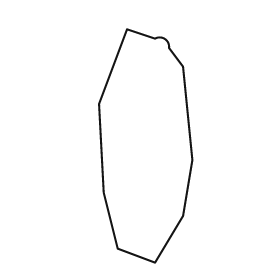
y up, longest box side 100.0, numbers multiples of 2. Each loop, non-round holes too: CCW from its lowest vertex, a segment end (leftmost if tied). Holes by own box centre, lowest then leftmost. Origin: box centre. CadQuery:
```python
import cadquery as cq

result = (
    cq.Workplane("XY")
    .moveTo(4.0, -50.0)
    .lineTo(16.0, -30.0)
    .lineTo(20.0, -6.0)
    .lineTo(16.0, 34.0)
    .lineTo(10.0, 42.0)
    .threePointArc((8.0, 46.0), (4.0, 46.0))
    .lineTo(-8.0, 50.0)
    .lineTo(-20.0, 18.0)
    .lineTo(-18.0, -20.0)
    .lineTo(-12.0, -44.0)
    .close()
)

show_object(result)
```